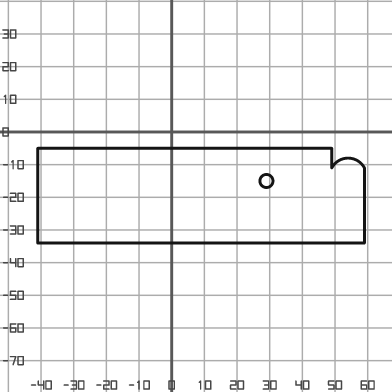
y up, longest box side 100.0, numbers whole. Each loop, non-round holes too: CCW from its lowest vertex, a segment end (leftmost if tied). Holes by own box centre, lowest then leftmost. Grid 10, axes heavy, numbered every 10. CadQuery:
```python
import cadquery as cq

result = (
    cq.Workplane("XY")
    .moveTo(-41.0, -34.0)
    .lineTo(59.0, -34.0)
    .lineTo(59.0, -11.0)
    .threePointArc((54.0, -8.0), (49.0, -11.0))
    .lineTo(49.0, -5.0)
    .lineTo(-41.0, -5.0)
    .close()
    .moveTo(29.0, -15.0)
    .circle(2.0)
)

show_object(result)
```